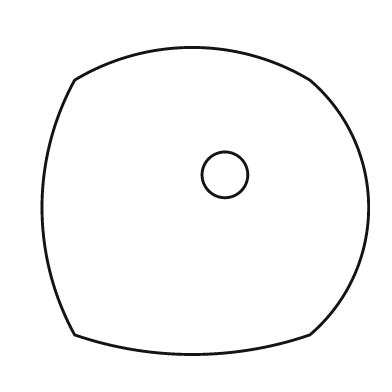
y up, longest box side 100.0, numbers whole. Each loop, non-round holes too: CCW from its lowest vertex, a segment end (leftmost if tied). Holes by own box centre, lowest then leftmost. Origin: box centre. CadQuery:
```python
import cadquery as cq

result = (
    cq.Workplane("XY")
    .moveTo(-40.0, -41.0)
    .threePointArc((-4.0, -47.0), (32.0, -41.0))
    .threePointArc((50.0, -2.0), (32.0, 37.0))
    .threePointArc((-4.0, 47.0), (-40.0, 37.0))
    .threePointArc((-50.0, -2.0), (-40.0, -41.0))
    .close()
    .moveTo(6.0, 8.0)
    .circle(7.0)
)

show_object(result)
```